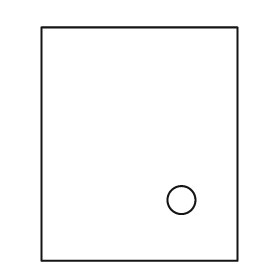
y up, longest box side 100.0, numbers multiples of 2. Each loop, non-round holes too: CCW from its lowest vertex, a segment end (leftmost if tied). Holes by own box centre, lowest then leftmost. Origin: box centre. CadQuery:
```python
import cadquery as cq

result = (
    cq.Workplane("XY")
    .moveTo(-42.0, -50.0)
    .lineTo(42.0, -50.0)
    .lineTo(42.0, 50.0)
    .lineTo(-42.0, 50.0)
    .close()
    .moveTo(18.0, -24.0)
    .circle(6.0)
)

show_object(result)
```